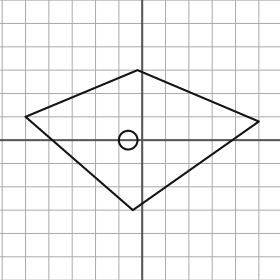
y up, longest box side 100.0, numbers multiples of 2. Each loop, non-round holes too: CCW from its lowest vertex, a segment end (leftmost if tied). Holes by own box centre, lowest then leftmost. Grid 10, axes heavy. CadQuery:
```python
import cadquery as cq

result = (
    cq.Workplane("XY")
    .moveTo(-4.0, -30.0)
    .lineTo(50.0, 8.0)
    .lineTo(-2.0, 30.0)
    .lineTo(-50.0, 10.0)
    .close()
    .moveTo(-6.0, 0.0)
    .circle(4.0)
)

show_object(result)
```